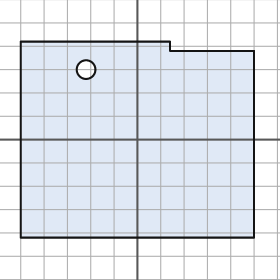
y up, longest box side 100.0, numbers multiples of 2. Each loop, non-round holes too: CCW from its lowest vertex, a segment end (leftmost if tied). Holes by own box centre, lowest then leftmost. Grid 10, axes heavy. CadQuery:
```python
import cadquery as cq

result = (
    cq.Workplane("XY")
    .moveTo(-50.0, -42.0)
    .lineTo(50.0, -42.0)
    .lineTo(50.0, 38.0)
    .lineTo(14.0, 38.0)
    .lineTo(14.0, 42.0)
    .lineTo(-50.0, 42.0)
    .close()
    .moveTo(-22.0, 30.0)
    .circle(4.0)
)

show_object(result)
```